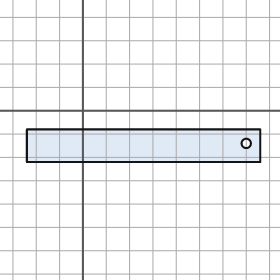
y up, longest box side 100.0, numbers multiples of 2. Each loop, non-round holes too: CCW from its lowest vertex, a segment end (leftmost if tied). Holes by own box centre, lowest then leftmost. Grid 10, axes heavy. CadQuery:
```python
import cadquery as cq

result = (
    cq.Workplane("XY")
    .moveTo(-24.0, -22.0)
    .lineTo(76.0, -22.0)
    .lineTo(76.0, -8.0)
    .lineTo(-24.0, -8.0)
    .close()
    .moveTo(70.0, -14.0)
    .circle(2.0)
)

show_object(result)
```